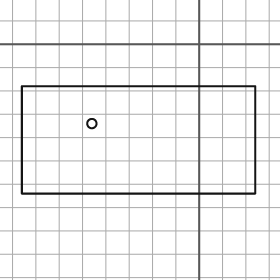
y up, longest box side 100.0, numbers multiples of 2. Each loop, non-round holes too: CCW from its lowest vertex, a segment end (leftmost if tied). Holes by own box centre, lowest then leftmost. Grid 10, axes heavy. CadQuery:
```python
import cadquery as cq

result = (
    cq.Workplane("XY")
    .moveTo(-76.0, -64.0)
    .lineTo(24.0, -64.0)
    .lineTo(24.0, -18.0)
    .lineTo(-76.0, -18.0)
    .close()
    .moveTo(-46.0, -34.0)
    .circle(2.0)
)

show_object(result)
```